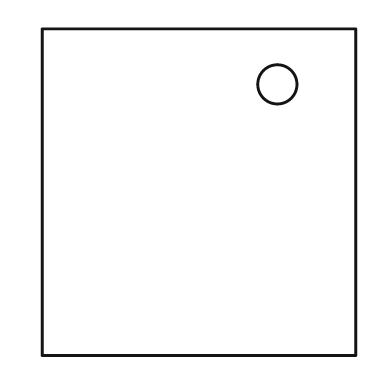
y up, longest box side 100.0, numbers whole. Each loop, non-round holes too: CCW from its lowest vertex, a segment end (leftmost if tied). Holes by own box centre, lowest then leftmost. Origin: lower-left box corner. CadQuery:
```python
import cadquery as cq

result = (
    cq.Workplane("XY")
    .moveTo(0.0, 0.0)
    .lineTo(96.0, 0.0)
    .lineTo(96.0, 100.0)
    .lineTo(0.0, 100.0)
    .close()
    .moveTo(72.0, 83.0)
    .circle(6.0)
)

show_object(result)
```